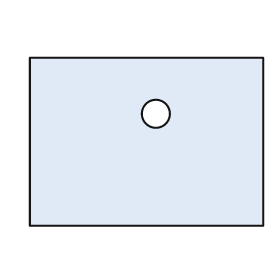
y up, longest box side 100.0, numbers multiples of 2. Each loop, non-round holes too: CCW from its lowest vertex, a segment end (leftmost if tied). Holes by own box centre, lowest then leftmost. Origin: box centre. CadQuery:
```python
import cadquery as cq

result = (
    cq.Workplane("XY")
    .moveTo(-50.0, -36.0)
    .lineTo(50.0, -36.0)
    .lineTo(50.0, 36.0)
    .lineTo(-50.0, 36.0)
    .close()
    .moveTo(4.0, 12.0)
    .circle(6.0)
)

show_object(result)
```